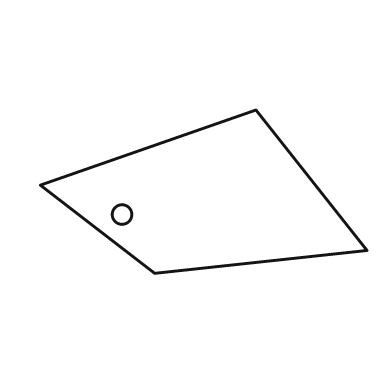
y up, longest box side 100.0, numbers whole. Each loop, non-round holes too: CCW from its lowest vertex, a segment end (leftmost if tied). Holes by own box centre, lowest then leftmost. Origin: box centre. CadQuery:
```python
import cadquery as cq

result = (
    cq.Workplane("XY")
    .moveTo(-15.0, -25.0)
    .lineTo(50.0, -18.0)
    .lineTo(16.0, 25.0)
    .lineTo(-50.0, 2.0)
    .close()
    .moveTo(-25.0, -7.0)
    .circle(3.0)
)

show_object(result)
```